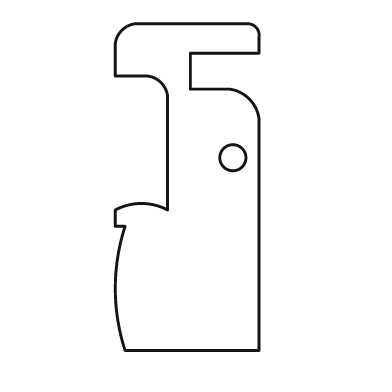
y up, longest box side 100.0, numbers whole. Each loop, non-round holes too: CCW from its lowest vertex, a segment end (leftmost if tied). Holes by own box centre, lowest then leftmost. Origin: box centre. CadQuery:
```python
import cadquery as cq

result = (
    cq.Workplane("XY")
    .moveTo(-19.0, -50.0)
    .lineTo(22.0, -50.0)
    .lineTo(22.0, 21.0)
    .threePointArc((19.0, 27.0), (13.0, 30.0))
    .lineTo(1.0, 30.0)
    .lineTo(1.0, 41.0)
    .lineTo(22.0, 41.0)
    .lineTo(22.0, 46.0)
    .threePointArc((21.0, 49.0), (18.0, 50.0))
    .lineTo(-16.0, 50.0)
    .threePointArc((-20.0, 48.0), (-22.0, 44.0))
    .lineTo(-22.0, 34.0)
    .lineTo(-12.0, 34.0)
    .threePointArc((-8.0, 32.0), (-6.0, 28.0))
    .lineTo(-6.0, -7.0)
    .threePointArc((-14.0, -5.0), (-22.0, -7.0))
    .lineTo(-22.0, -12.0)
    .lineTo(-19.0, -12.0)
    .threePointArc((-22.0, -31.0), (-19.0, -50.0))
    .close()
    .moveTo(14.0, 9.0)
    .circle(4.0)
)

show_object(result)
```